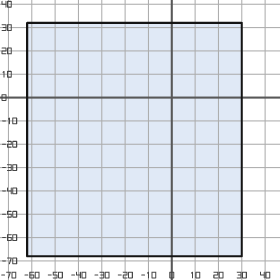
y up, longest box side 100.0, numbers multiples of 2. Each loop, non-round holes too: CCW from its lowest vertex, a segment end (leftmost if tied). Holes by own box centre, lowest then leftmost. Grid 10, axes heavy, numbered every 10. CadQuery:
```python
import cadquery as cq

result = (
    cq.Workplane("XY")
    .moveTo(-62.0, -68.0)
    .lineTo(30.0, -68.0)
    .lineTo(30.0, 32.0)
    .lineTo(-62.0, 32.0)
    .close()
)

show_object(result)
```